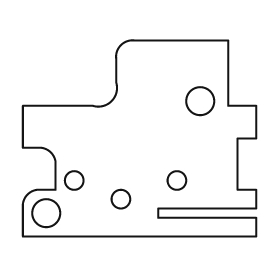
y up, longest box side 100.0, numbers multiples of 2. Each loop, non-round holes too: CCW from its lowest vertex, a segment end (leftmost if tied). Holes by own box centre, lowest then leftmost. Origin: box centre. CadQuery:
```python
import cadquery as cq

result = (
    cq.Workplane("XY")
    .moveTo(-50.0, -42.0)
    .lineTo(50.0, -42.0)
    .lineTo(50.0, -34.0)
    .lineTo(8.0, -34.0)
    .lineTo(8.0, -30.0)
    .lineTo(50.0, -30.0)
    .lineTo(50.0, -22.0)
    .lineTo(42.0, -22.0)
    .lineTo(42.0, 0.0)
    .lineTo(50.0, 0.0)
    .lineTo(50.0, 14.0)
    .lineTo(38.0, 14.0)
    .lineTo(38.0, 42.0)
    .lineTo(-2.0, 42.0)
    .threePointArc((-8.0, 40.0), (-10.0, 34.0))
    .lineTo(-10.0, 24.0)
    .threePointArc((-12.0, 16.0), (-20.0, 14.0))
    .lineTo(-50.0, 14.0)
    .lineTo(-50.0, -4.0)
    .lineTo(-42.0, -4.0)
    .threePointArc((-38.0, -6.0), (-36.0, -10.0))
    .lineTo(-36.0, -22.0)
    .lineTo(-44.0, -22.0)
    .threePointArc((-48.0, -24.0), (-50.0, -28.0))
    .close()
    .moveTo(-40.0, -32.0)
    .circle(6.0)
    .moveTo(-8.0, -26.0)
    .circle(4.0)
    .moveTo(-28.0, -18.0)
    .circle(4.0)
    .moveTo(16.0, -18.0)
    .circle(4.0)
    .moveTo(26.0, 16.0)
    .circle(6.0)
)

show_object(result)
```